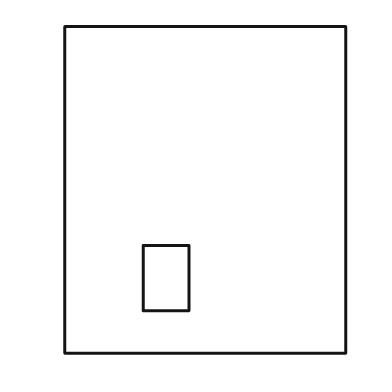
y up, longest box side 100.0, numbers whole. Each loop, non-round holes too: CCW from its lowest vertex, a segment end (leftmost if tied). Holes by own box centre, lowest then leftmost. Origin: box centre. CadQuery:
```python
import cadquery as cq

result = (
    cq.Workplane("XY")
    .moveTo(-43.0, -50.0)
    .lineTo(43.0, -50.0)
    .lineTo(43.0, 50.0)
    .lineTo(-43.0, 50.0)
    .close()
    .moveTo(-19.0, -37.0)
    .lineTo(-5.0, -37.0)
    .lineTo(-5.0, -17.0)
    .lineTo(-19.0, -17.0)
    .close()
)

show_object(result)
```